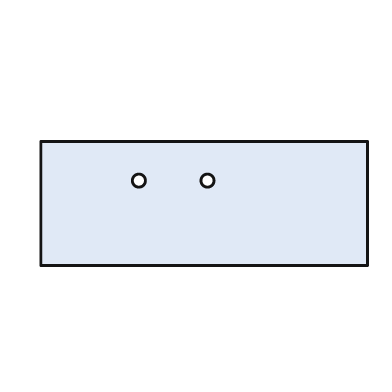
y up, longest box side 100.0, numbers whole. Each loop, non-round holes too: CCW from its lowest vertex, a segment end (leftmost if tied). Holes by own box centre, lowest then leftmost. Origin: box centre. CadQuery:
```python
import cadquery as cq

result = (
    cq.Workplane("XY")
    .moveTo(-50.0, -19.0)
    .lineTo(50.0, -19.0)
    .lineTo(50.0, 19.0)
    .lineTo(-50.0, 19.0)
    .close()
    .moveTo(-20.0, 7.0)
    .circle(2.0)
    .moveTo(1.0, 7.0)
    .circle(2.0)
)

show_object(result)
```